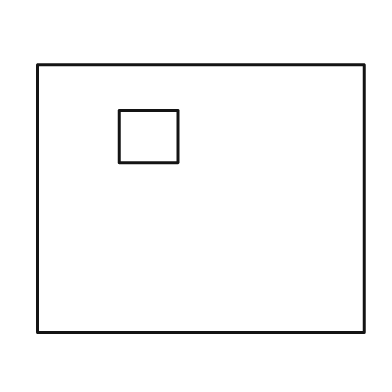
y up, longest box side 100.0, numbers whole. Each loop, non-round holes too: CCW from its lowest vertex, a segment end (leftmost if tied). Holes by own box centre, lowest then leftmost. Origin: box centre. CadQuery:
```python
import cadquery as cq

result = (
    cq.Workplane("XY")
    .moveTo(-50.0, -41.0)
    .lineTo(50.0, -41.0)
    .lineTo(50.0, 41.0)
    .lineTo(-50.0, 41.0)
    .close()
    .moveTo(-25.0, 11.0)
    .lineTo(-7.0, 11.0)
    .lineTo(-7.0, 27.0)
    .lineTo(-25.0, 27.0)
    .close()
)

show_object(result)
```